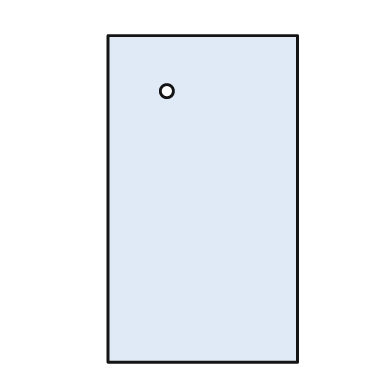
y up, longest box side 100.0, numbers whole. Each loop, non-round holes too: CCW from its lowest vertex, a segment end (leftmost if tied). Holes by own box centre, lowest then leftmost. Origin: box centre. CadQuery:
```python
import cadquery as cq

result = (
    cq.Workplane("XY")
    .moveTo(-29.0, -50.0)
    .lineTo(29.0, -50.0)
    .lineTo(29.0, 50.0)
    .lineTo(-29.0, 50.0)
    .close()
    .moveTo(-11.0, 33.0)
    .circle(2.0)
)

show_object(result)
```